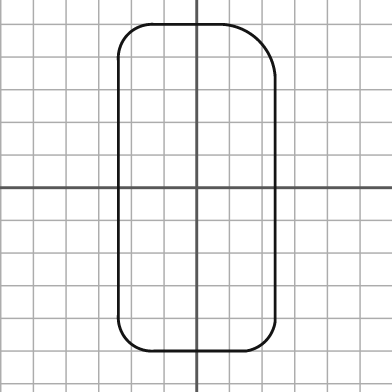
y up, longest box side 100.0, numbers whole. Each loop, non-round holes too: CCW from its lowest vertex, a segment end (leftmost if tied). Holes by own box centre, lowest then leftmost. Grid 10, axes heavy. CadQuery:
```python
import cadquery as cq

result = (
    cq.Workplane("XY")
    .moveTo(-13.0, -50.0)
    .lineTo(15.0, -50.0)
    .threePointArc((21.0, -47.0), (24.0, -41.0))
    .lineTo(24.0, 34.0)
    .threePointArc((19.0, 45.0), (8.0, 50.0))
    .lineTo(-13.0, 50.0)
    .threePointArc((-21.0, 47.0), (-24.0, 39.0))
    .lineTo(-24.0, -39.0)
    .threePointArc((-21.0, -47.0), (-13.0, -50.0))
    .close()
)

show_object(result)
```